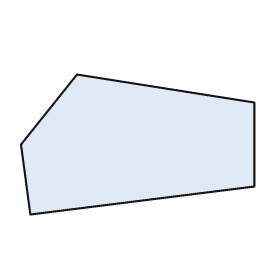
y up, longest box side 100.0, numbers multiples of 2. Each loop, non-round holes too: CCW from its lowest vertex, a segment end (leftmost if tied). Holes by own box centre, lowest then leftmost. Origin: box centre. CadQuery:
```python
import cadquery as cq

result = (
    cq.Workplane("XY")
    .moveTo(-46.0, -30.0)
    .lineTo(50.0, -18.0)
    .lineTo(50.0, 18.0)
    .lineTo(-26.0, 30.0)
    .lineTo(-50.0, 0.0)
    .close()
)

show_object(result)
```